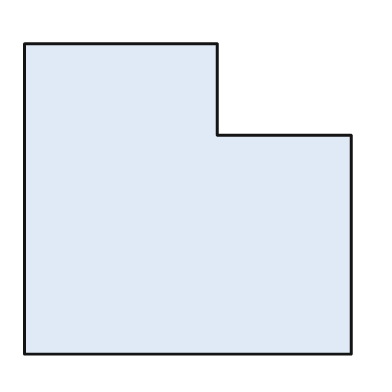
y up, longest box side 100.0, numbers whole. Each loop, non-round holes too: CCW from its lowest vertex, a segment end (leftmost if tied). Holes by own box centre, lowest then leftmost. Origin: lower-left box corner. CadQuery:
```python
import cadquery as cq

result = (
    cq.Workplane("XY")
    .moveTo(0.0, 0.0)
    .lineTo(100.0, 0.0)
    .lineTo(100.0, 67.0)
    .lineTo(59.0, 67.0)
    .lineTo(59.0, 95.0)
    .lineTo(0.0, 95.0)
    .close()
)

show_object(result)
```